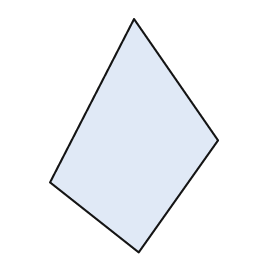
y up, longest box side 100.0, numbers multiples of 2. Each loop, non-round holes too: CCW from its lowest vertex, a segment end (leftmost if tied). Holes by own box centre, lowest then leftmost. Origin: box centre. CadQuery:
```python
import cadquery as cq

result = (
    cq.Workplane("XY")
    .moveTo(2.0, -50.0)
    .lineTo(36.0, -2.0)
    .lineTo(0.0, 50.0)
    .lineTo(-36.0, -20.0)
    .close()
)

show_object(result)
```